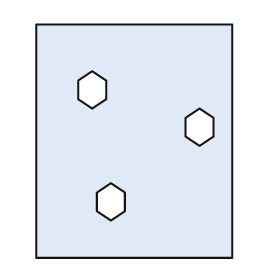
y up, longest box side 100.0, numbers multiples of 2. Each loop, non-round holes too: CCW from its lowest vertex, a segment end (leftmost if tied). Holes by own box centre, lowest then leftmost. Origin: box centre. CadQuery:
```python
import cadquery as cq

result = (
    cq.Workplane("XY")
    .moveTo(-42.0, -50.0)
    .lineTo(42.0, -50.0)
    .lineTo(42.0, 50.0)
    .lineTo(-42.0, 50.0)
    .close()
    .moveTo(-10.0, -34.0)
    .lineTo(-4.0, -30.0)
    .lineTo(-4.0, -22.0)
    .lineTo(-10.0, -18.0)
    .lineTo(-16.0, -22.0)
    .lineTo(-16.0, -30.0)
    .close()
    .moveTo(28.0, -2.0)
    .lineTo(34.0, 2.0)
    .lineTo(34.0, 10.0)
    .lineTo(28.0, 14.0)
    .lineTo(22.0, 10.0)
    .lineTo(22.0, 2.0)
    .close()
    .moveTo(-18.0, 14.0)
    .lineTo(-12.0, 18.0)
    .lineTo(-12.0, 26.0)
    .lineTo(-18.0, 30.0)
    .lineTo(-24.0, 26.0)
    .lineTo(-24.0, 18.0)
    .close()
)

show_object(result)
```